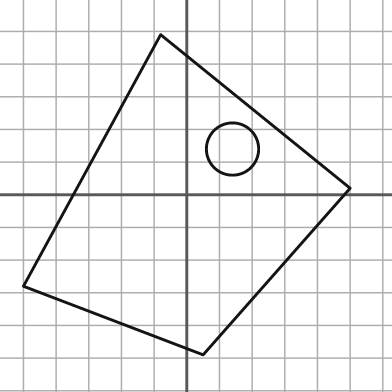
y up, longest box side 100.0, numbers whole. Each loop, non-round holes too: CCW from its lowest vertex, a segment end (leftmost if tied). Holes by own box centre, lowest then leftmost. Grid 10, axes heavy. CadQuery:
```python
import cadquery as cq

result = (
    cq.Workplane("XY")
    .moveTo(5.0, -49.0)
    .lineTo(50.0, 2.0)
    .lineTo(-8.0, 49.0)
    .lineTo(-50.0, -28.0)
    .close()
    .moveTo(14.0, 14.0)
    .circle(8.0)
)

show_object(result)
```